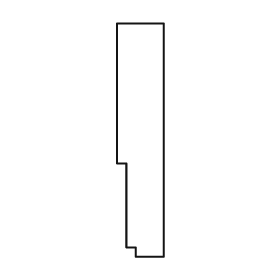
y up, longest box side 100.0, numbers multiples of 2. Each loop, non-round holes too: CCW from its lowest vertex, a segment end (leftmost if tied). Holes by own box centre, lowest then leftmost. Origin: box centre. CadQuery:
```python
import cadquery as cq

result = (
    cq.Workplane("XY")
    .moveTo(-2.0, -50.0)
    .lineTo(10.0, -50.0)
    .lineTo(10.0, 50.0)
    .lineTo(-10.0, 50.0)
    .lineTo(-10.0, -10.0)
    .lineTo(-6.0, -10.0)
    .lineTo(-6.0, -46.0)
    .lineTo(-2.0, -46.0)
    .close()
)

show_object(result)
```